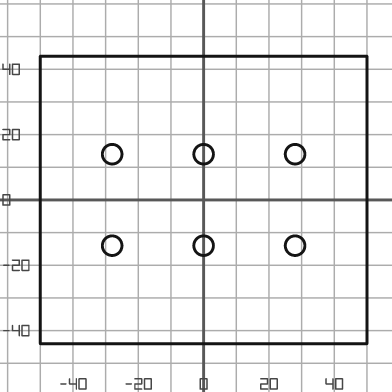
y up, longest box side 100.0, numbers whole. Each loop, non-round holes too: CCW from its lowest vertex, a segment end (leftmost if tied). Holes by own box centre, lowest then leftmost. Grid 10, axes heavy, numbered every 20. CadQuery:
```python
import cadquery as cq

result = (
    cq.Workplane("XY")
    .moveTo(-50.0, -44.0)
    .lineTo(50.0, -44.0)
    .lineTo(50.0, 44.0)
    .lineTo(-50.0, 44.0)
    .close()
    .moveTo(-28.0, -14.0)
    .circle(3.0)
    .moveTo(0.0, -14.0)
    .circle(3.0)
    .moveTo(28.0, -14.0)
    .circle(3.0)
    .moveTo(-28.0, 14.0)
    .circle(3.0)
    .moveTo(0.0, 14.0)
    .circle(3.0)
    .moveTo(28.0, 14.0)
    .circle(3.0)
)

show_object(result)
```